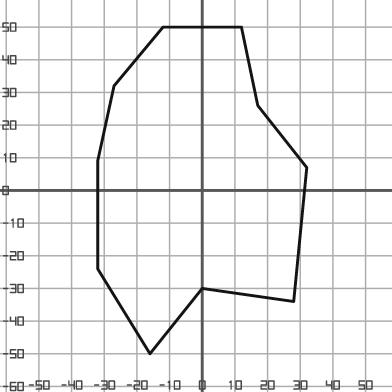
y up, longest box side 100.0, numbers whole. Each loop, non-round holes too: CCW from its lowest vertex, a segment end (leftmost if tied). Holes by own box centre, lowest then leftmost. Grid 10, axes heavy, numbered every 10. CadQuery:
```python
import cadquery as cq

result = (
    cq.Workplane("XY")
    .moveTo(-16.0, -50.0)
    .lineTo(0.0, -30.0)
    .lineTo(28.0, -34.0)
    .lineTo(32.0, 7.0)
    .lineTo(17.0, 26.0)
    .lineTo(12.0, 50.0)
    .lineTo(-12.0, 50.0)
    .lineTo(-27.0, 32.0)
    .lineTo(-32.0, 9.0)
    .lineTo(-32.0, -24.0)
    .close()
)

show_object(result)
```